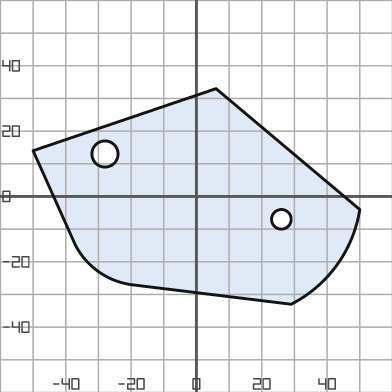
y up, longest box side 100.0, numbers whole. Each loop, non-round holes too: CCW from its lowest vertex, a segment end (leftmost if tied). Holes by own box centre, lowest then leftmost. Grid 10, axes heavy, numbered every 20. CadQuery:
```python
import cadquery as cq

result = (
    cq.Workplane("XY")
    .moveTo(29.0, -33.0)
    .threePointArc((43.0, -21.0), (50.0, -4.0))
    .lineTo(6.0, 33.0)
    .lineTo(-50.0, 14.0)
    .lineTo(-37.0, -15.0)
    .threePointArc((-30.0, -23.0), (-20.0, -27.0))
    .close()
    .moveTo(26.0, -7.0)
    .circle(3.0)
    .moveTo(-28.0, 13.0)
    .circle(4.0)
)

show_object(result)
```